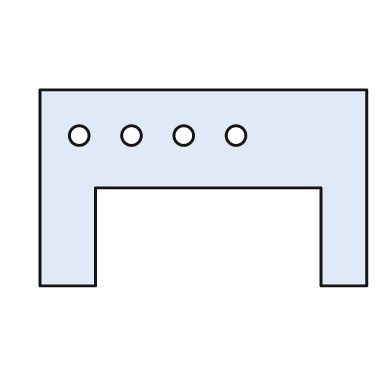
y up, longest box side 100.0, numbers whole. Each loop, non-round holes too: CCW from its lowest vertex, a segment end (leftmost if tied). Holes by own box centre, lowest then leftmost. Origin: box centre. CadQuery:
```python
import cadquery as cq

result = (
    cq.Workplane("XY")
    .moveTo(-50.0, -30.0)
    .lineTo(-33.0, -30.0)
    .lineTo(-33.0, 0.0)
    .lineTo(36.0, 0.0)
    .lineTo(36.0, -30.0)
    .lineTo(50.0, -30.0)
    .lineTo(50.0, 30.0)
    .lineTo(-50.0, 30.0)
    .close()
    .moveTo(-38.0, 16.0)
    .circle(3.0)
    .moveTo(-22.0, 16.0)
    .circle(3.0)
    .moveTo(-6.0, 16.0)
    .circle(3.0)
    .moveTo(10.0, 16.0)
    .circle(3.0)
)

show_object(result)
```